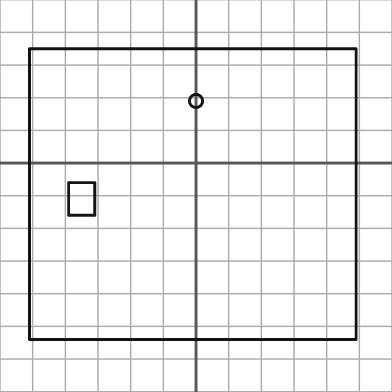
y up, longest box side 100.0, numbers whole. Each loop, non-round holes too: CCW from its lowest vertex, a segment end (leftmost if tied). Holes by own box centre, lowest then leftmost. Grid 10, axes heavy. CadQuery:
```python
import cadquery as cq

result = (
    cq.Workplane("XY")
    .moveTo(-51.0, -54.0)
    .lineTo(49.0, -54.0)
    .lineTo(49.0, 35.0)
    .lineTo(-51.0, 35.0)
    .close()
    .moveTo(-39.0, -16.0)
    .lineTo(-31.0, -16.0)
    .lineTo(-31.0, -6.0)
    .lineTo(-39.0, -6.0)
    .close()
    .moveTo(0.0, 19.0)
    .circle(2.0)
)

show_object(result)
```